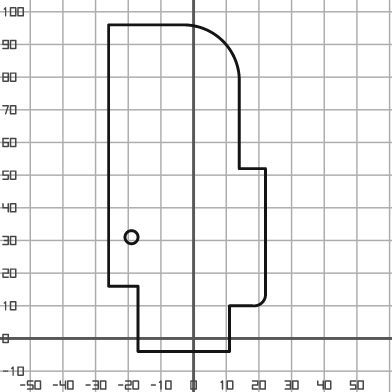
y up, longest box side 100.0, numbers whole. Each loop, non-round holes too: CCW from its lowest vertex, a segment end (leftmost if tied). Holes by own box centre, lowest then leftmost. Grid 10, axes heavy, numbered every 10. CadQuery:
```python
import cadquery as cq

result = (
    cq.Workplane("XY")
    .moveTo(-17.0, -4.0)
    .lineTo(11.0, -4.0)
    .lineTo(11.0, 10.0)
    .lineTo(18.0, 10.0)
    .threePointArc((21.0, 11.0), (22.0, 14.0))
    .lineTo(22.0, 52.0)
    .lineTo(14.0, 52.0)
    .lineTo(14.0, 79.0)
    .threePointArc((9.0, 91.0), (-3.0, 96.0))
    .lineTo(-26.0, 96.0)
    .lineTo(-26.0, 16.0)
    .lineTo(-17.0, 16.0)
    .close()
    .moveTo(-19.0, 31.0)
    .circle(2.0)
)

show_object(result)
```